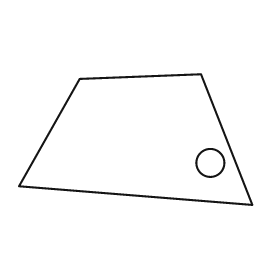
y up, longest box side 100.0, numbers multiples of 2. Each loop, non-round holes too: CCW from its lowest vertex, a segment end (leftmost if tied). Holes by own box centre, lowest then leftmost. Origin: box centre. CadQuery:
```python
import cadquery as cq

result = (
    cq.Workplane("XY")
    .moveTo(50.0, -28.0)
    .lineTo(28.0, 28.0)
    .lineTo(-24.0, 26.0)
    .lineTo(-50.0, -20.0)
    .close()
    .moveTo(32.0, -10.0)
    .circle(6.0)
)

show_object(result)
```